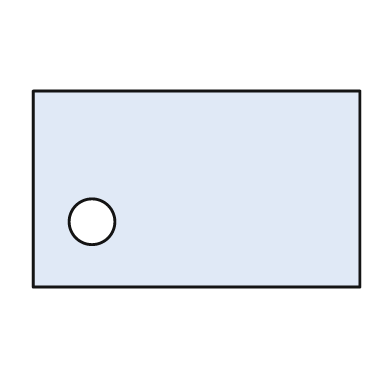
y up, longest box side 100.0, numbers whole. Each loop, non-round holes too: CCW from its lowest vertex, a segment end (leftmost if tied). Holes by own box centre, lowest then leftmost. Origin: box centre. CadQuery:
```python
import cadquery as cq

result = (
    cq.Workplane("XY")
    .moveTo(-50.0, -30.0)
    .lineTo(50.0, -30.0)
    .lineTo(50.0, 30.0)
    .lineTo(-50.0, 30.0)
    .close()
    .moveTo(-32.0, -10.0)
    .circle(7.0)
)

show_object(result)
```